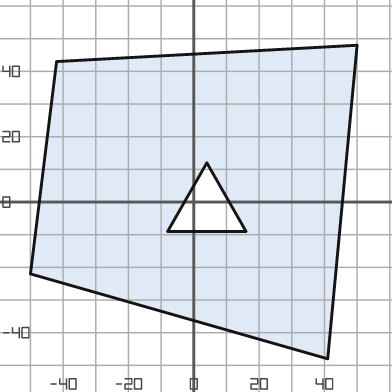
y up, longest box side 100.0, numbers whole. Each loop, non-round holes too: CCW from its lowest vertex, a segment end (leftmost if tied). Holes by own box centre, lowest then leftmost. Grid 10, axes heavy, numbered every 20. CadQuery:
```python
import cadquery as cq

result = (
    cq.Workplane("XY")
    .moveTo(41.0, -48.0)
    .lineTo(50.0, 48.0)
    .lineTo(-42.0, 43.0)
    .lineTo(-50.0, -22.0)
    .close()
    .moveTo(-8.0, -9.0)
    .lineTo(16.0, -9.0)
    .lineTo(4.0, 12.0)
    .close()
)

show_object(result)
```